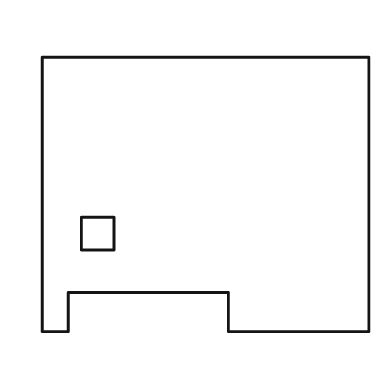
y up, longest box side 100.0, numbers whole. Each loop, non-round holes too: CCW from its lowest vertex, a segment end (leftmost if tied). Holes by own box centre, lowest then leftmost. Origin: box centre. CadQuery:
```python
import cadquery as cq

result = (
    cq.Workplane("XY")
    .moveTo(-50.0, -42.0)
    .lineTo(-42.0, -42.0)
    .lineTo(-42.0, -30.0)
    .lineTo(7.0, -30.0)
    .lineTo(7.0, -42.0)
    .lineTo(50.0, -42.0)
    .lineTo(50.0, 42.0)
    .lineTo(-50.0, 42.0)
    .close()
    .moveTo(-38.0, -17.0)
    .lineTo(-28.0, -17.0)
    .lineTo(-28.0, -7.0)
    .lineTo(-38.0, -7.0)
    .close()
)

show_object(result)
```